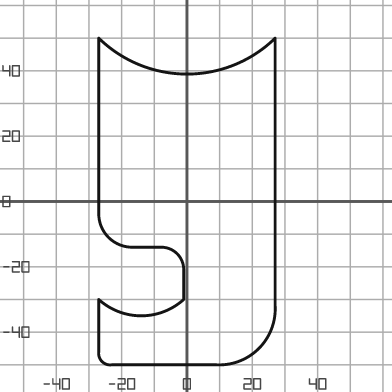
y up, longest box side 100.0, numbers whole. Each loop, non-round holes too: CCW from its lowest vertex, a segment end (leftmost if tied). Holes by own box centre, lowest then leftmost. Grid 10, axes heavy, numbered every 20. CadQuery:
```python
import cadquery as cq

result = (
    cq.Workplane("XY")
    .moveTo(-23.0, -50.0)
    .lineTo(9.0, -50.0)
    .threePointArc((22.0, -45.0), (27.0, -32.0))
    .lineTo(27.0, 50.0)
    .threePointArc((0.0, 39.0), (-27.0, 50.0))
    .lineTo(-27.0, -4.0)
    .threePointArc((-24.0, -11.0), (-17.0, -14.0))
    .lineTo(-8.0, -14.0)
    .threePointArc((-3.0, -16.0), (-1.0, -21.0))
    .lineTo(-1.0, -30.0)
    .threePointArc((-14.0, -35.0), (-27.0, -30.0))
    .lineTo(-27.0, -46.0)
    .threePointArc((-26.0, -49.0), (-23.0, -50.0))
    .close()
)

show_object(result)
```